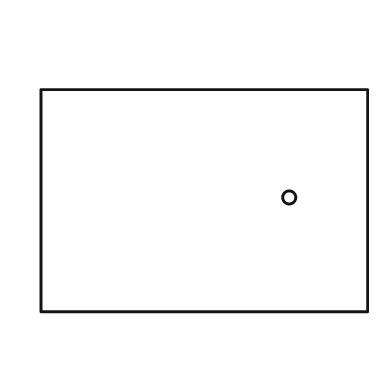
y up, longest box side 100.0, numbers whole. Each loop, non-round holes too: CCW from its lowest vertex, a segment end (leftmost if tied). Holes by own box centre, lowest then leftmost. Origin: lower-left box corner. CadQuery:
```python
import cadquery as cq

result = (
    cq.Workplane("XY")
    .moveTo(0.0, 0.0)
    .lineTo(100.0, 0.0)
    .lineTo(100.0, 68.0)
    .lineTo(0.0, 68.0)
    .close()
    .moveTo(76.0, 35.0)
    .circle(2.0)
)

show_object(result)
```